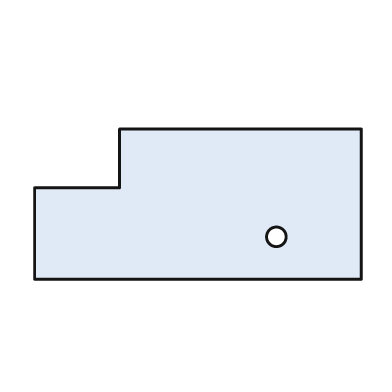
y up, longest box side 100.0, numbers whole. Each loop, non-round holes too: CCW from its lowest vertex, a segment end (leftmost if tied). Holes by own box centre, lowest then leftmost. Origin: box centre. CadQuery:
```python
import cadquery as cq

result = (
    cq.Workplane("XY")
    .moveTo(-50.0, -23.0)
    .lineTo(50.0, -23.0)
    .lineTo(50.0, 23.0)
    .lineTo(-24.0, 23.0)
    .lineTo(-24.0, 5.0)
    .lineTo(-50.0, 5.0)
    .close()
    .moveTo(24.0, -10.0)
    .circle(3.0)
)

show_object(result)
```